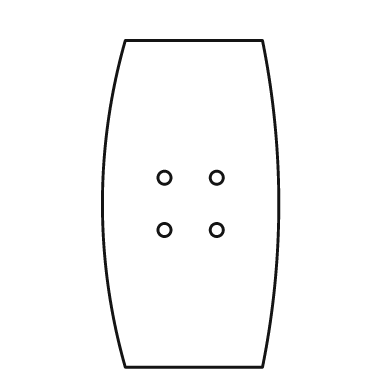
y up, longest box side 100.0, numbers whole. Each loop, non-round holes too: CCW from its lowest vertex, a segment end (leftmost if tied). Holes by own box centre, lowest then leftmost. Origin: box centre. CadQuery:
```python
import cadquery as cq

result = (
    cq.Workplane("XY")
    .moveTo(-20.0, -50.0)
    .lineTo(22.0, -50.0)
    .threePointArc((27.0, 0.0), (22.0, 50.0))
    .lineTo(-20.0, 50.0)
    .threePointArc((-27.0, 0.0), (-20.0, -50.0))
    .close()
    .moveTo(-8.0, -8.0)
    .circle(2.0)
    .moveTo(8.0, -8.0)
    .circle(2.0)
    .moveTo(-8.0, 8.0)
    .circle(2.0)
    .moveTo(8.0, 8.0)
    .circle(2.0)
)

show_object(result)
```